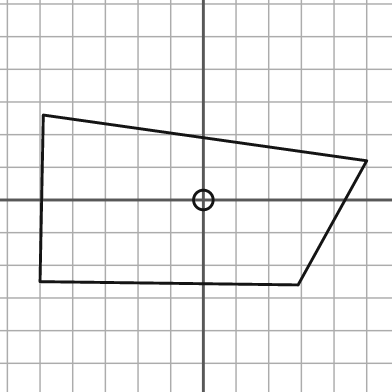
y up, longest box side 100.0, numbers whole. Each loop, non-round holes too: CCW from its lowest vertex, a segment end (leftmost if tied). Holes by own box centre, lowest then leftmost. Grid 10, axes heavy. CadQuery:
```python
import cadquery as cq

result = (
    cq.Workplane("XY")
    .moveTo(29.0, -26.0)
    .lineTo(50.0, 12.0)
    .lineTo(-49.0, 26.0)
    .lineTo(-50.0, -25.0)
    .close()
    .moveTo(0.0, 0.0)
    .circle(3.0)
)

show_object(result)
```